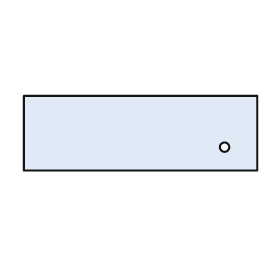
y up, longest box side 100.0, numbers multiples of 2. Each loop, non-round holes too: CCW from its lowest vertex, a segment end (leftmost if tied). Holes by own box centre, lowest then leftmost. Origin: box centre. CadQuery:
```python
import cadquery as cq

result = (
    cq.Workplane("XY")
    .moveTo(-50.0, -16.0)
    .lineTo(50.0, -16.0)
    .lineTo(50.0, 16.0)
    .lineTo(-50.0, 16.0)
    .close()
    .moveTo(36.0, -6.0)
    .circle(2.0)
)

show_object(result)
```